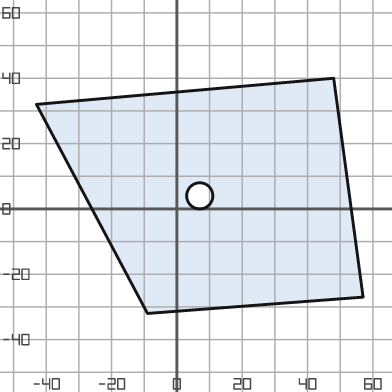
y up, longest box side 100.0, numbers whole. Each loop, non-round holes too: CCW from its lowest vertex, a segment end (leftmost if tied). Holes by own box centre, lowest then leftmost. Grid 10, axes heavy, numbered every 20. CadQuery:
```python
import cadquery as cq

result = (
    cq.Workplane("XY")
    .moveTo(-9.0, -32.0)
    .lineTo(57.0, -27.0)
    .lineTo(48.0, 40.0)
    .lineTo(-43.0, 32.0)
    .close()
    .moveTo(7.0, 4.0)
    .circle(4.0)
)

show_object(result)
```